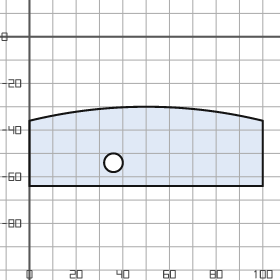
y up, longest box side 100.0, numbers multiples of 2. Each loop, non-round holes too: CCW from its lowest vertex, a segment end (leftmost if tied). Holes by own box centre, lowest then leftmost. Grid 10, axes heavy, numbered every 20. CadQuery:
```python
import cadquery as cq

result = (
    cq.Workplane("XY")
    .moveTo(0.0, -64.0)
    .lineTo(100.0, -64.0)
    .lineTo(100.0, -36.0)
    .threePointArc((50.0, -30.0), (0.0, -36.0))
    .close()
    .moveTo(36.0, -54.0)
    .circle(4.0)
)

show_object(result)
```